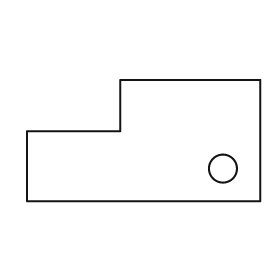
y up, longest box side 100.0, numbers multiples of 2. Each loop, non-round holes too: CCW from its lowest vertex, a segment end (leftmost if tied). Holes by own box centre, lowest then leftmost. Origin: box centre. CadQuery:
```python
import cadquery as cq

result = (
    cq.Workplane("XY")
    .moveTo(-50.0, -26.0)
    .lineTo(50.0, -26.0)
    .lineTo(50.0, 26.0)
    .lineTo(-10.0, 26.0)
    .lineTo(-10.0, 4.0)
    .lineTo(-50.0, 4.0)
    .close()
    .moveTo(34.0, -12.0)
    .circle(6.0)
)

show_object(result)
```